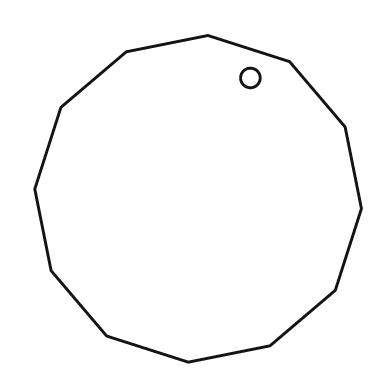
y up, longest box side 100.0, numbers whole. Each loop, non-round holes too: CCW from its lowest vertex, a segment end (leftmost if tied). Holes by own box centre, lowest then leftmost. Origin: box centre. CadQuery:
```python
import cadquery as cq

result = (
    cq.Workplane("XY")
    .moveTo(-3.0, -50.0)
    .lineTo(22.0, -45.0)
    .lineTo(42.0, -28.0)
    .lineTo(50.0, -3.0)
    .lineTo(45.0, 22.0)
    .lineTo(28.0, 42.0)
    .lineTo(3.0, 50.0)
    .lineTo(-22.0, 45.0)
    .lineTo(-42.0, 28.0)
    .lineTo(-50.0, 3.0)
    .lineTo(-45.0, -22.0)
    .lineTo(-28.0, -42.0)
    .close()
    .moveTo(16.0, 37.0)
    .circle(3.0)
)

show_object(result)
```